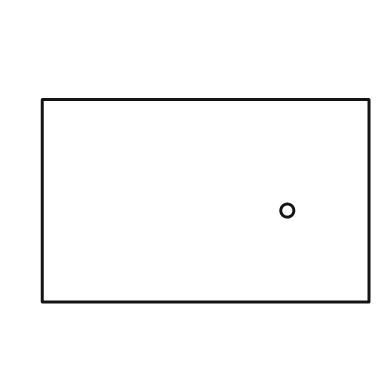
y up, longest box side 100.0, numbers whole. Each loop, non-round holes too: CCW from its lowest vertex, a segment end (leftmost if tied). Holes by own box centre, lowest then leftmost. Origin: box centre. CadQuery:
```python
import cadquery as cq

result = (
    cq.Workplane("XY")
    .moveTo(-50.0, -31.0)
    .lineTo(50.0, -31.0)
    .lineTo(50.0, 31.0)
    .lineTo(-50.0, 31.0)
    .close()
    .moveTo(25.0, -3.0)
    .circle(2.0)
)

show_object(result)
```